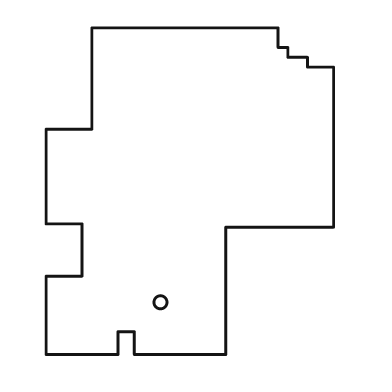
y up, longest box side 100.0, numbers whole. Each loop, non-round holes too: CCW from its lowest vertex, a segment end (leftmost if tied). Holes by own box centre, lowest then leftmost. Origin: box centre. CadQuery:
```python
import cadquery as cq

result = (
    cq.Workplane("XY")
    .moveTo(-44.0, -50.0)
    .lineTo(-22.0, -50.0)
    .lineTo(-22.0, -43.0)
    .lineTo(-17.0, -43.0)
    .lineTo(-17.0, -50.0)
    .lineTo(11.0, -50.0)
    .lineTo(11.0, -11.0)
    .lineTo(44.0, -11.0)
    .lineTo(44.0, 38.0)
    .lineTo(36.0, 38.0)
    .lineTo(36.0, 41.0)
    .lineTo(30.0, 41.0)
    .lineTo(30.0, 44.0)
    .lineTo(27.0, 44.0)
    .lineTo(27.0, 50.0)
    .lineTo(-30.0, 50.0)
    .lineTo(-30.0, 19.0)
    .lineTo(-44.0, 19.0)
    .lineTo(-44.0, -10.0)
    .lineTo(-33.0, -10.0)
    .lineTo(-33.0, -26.0)
    .lineTo(-44.0, -26.0)
    .close()
    .moveTo(-9.0, -34.0)
    .circle(2.0)
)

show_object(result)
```